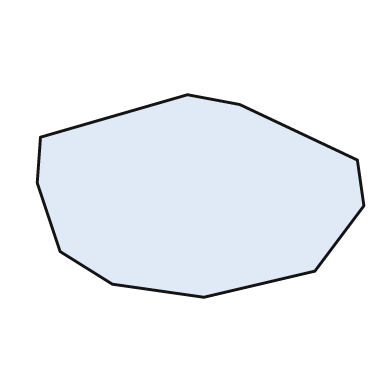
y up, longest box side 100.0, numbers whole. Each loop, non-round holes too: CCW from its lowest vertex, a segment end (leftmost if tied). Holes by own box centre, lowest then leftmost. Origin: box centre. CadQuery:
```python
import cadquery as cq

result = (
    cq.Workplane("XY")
    .moveTo(1.0, -31.0)
    .lineTo(35.0, -23.0)
    .lineTo(50.0, -3.0)
    .lineTo(48.0, 11.0)
    .lineTo(12.0, 28.0)
    .lineTo(-4.0, 31.0)
    .lineTo(-49.0, 18.0)
    .lineTo(-50.0, 4.0)
    .lineTo(-43.0, -17.0)
    .lineTo(-27.0, -27.0)
    .close()
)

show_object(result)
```